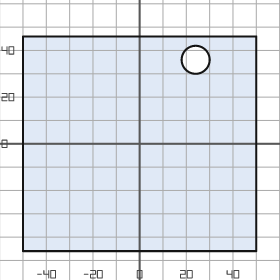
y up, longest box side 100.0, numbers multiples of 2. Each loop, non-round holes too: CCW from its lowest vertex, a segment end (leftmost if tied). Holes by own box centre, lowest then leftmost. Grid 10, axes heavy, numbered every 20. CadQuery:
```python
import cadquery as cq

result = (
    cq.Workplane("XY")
    .moveTo(-50.0, -46.0)
    .lineTo(50.0, -46.0)
    .lineTo(50.0, 46.0)
    .lineTo(-50.0, 46.0)
    .close()
    .moveTo(24.0, 36.0)
    .circle(6.0)
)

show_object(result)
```